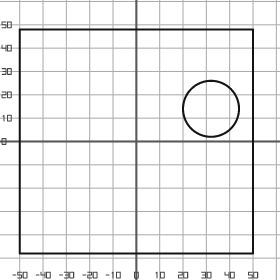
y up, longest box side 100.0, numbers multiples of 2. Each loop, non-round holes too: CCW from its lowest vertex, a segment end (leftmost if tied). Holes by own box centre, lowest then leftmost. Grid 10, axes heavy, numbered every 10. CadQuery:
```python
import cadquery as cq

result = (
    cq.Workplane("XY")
    .moveTo(-50.0, -48.0)
    .lineTo(50.0, -48.0)
    .lineTo(50.0, 48.0)
    .lineTo(-50.0, 48.0)
    .close()
    .moveTo(32.0, 14.0)
    .circle(12.0)
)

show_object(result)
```